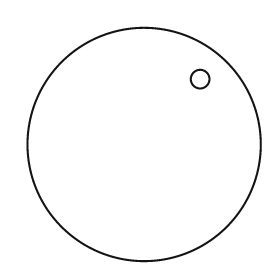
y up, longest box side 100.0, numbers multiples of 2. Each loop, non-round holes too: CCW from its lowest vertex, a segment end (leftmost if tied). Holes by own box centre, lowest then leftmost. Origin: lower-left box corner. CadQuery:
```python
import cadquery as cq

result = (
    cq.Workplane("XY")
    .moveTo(50.0, 50.0)
    .circle(50.0)
    .moveTo(74.0, 78.0)
    .circle(4.0)
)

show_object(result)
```